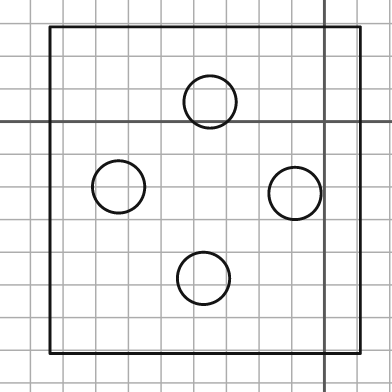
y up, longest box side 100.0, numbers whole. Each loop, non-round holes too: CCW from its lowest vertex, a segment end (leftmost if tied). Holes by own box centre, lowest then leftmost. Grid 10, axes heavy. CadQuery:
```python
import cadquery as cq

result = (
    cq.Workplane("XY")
    .moveTo(-84.0, -71.0)
    .lineTo(11.0, -71.0)
    .lineTo(11.0, 29.0)
    .lineTo(-84.0, 29.0)
    .close()
    .moveTo(-37.0, -48.0)
    .circle(8.0)
    .moveTo(-9.0, -22.0)
    .circle(8.0)
    .moveTo(-63.0, -20.0)
    .circle(8.0)
    .moveTo(-35.0, 6.0)
    .circle(8.0)
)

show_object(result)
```